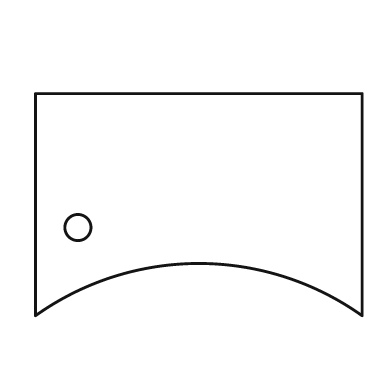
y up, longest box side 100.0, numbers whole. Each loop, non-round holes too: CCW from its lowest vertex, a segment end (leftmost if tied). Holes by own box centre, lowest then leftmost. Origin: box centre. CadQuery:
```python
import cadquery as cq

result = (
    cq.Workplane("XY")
    .moveTo(-50.0, -34.0)
    .threePointArc((0.0, -18.0), (50.0, -34.0))
    .lineTo(50.0, 34.0)
    .lineTo(-50.0, 34.0)
    .close()
    .moveTo(-37.0, -7.0)
    .circle(4.0)
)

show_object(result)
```